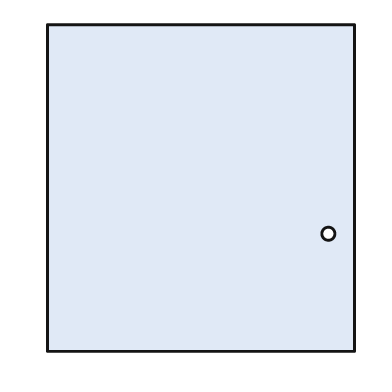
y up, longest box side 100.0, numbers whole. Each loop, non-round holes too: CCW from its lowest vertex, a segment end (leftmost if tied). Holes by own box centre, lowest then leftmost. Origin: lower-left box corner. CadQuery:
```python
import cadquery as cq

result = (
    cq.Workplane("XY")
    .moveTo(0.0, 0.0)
    .lineTo(94.0, 0.0)
    .lineTo(94.0, 100.0)
    .lineTo(0.0, 100.0)
    .close()
    .moveTo(86.0, 36.0)
    .circle(2.0)
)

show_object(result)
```